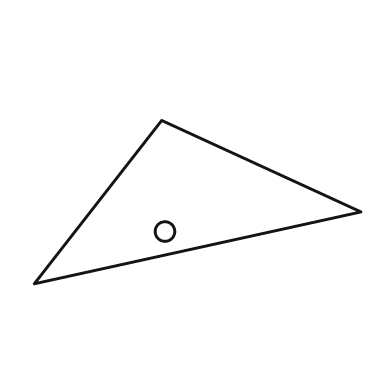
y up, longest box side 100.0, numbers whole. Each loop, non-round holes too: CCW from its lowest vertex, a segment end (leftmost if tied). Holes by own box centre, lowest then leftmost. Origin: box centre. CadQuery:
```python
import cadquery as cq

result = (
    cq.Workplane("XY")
    .moveTo(-50.0, -25.0)
    .lineTo(50.0, -3.0)
    .lineTo(-11.0, 25.0)
    .close()
    .moveTo(-10.0, -9.0)
    .circle(3.0)
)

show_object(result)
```